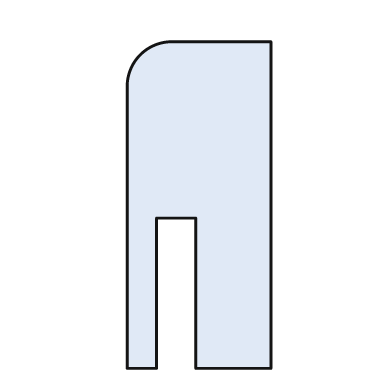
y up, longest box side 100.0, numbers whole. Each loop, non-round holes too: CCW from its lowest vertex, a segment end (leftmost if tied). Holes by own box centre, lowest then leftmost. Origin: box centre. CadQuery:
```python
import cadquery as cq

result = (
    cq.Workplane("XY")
    .moveTo(-22.0, -50.0)
    .lineTo(-13.0, -50.0)
    .lineTo(-13.0, -4.0)
    .lineTo(-1.0, -4.0)
    .lineTo(-1.0, -50.0)
    .lineTo(22.0, -50.0)
    .lineTo(22.0, 50.0)
    .lineTo(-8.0, 50.0)
    .threePointArc((-18.0, 46.0), (-22.0, 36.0))
    .close()
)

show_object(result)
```